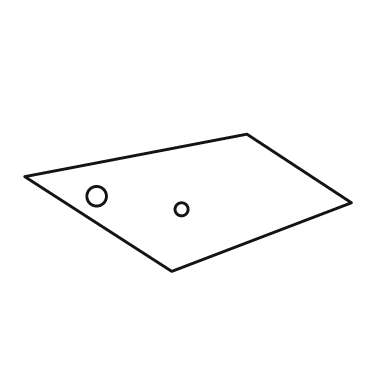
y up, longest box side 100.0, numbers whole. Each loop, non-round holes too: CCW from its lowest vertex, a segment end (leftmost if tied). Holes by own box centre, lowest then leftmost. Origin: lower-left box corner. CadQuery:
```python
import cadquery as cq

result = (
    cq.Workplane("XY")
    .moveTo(45.0, 0.0)
    .lineTo(100.0, 21.0)
    .lineTo(68.0, 42.0)
    .lineTo(0.0, 29.0)
    .close()
    .moveTo(48.0, 19.0)
    .circle(2.0)
    .moveTo(22.0, 23.0)
    .circle(3.0)
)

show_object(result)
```